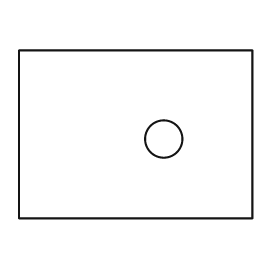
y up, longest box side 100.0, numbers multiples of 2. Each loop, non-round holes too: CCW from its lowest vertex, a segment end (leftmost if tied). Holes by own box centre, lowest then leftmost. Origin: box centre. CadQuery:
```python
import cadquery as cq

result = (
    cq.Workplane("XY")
    .moveTo(-50.0, -36.0)
    .lineTo(50.0, -36.0)
    .lineTo(50.0, 36.0)
    .lineTo(-50.0, 36.0)
    .close()
    .moveTo(12.0, -2.0)
    .circle(8.0)
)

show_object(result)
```